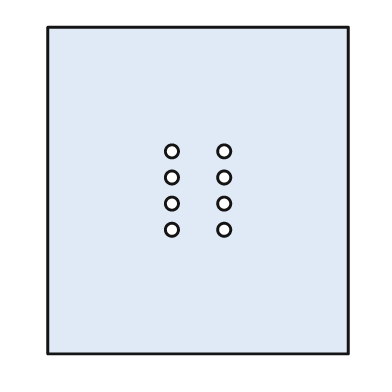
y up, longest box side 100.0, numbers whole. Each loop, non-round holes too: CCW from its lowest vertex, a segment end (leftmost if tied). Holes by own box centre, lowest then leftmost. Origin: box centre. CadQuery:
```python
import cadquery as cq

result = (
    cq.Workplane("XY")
    .moveTo(-46.0, -50.0)
    .lineTo(46.0, -50.0)
    .lineTo(46.0, 50.0)
    .lineTo(-46.0, 50.0)
    .close()
    .moveTo(-8.0, -12.0)
    .circle(2.0)
    .moveTo(8.0, -12.0)
    .circle(2.0)
    .moveTo(-8.0, -4.0)
    .circle(2.0)
    .moveTo(8.0, -4.0)
    .circle(2.0)
    .moveTo(-8.0, 4.0)
    .circle(2.0)
    .moveTo(8.0, 4.0)
    .circle(2.0)
    .moveTo(-8.0, 12.0)
    .circle(2.0)
    .moveTo(8.0, 12.0)
    .circle(2.0)
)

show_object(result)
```